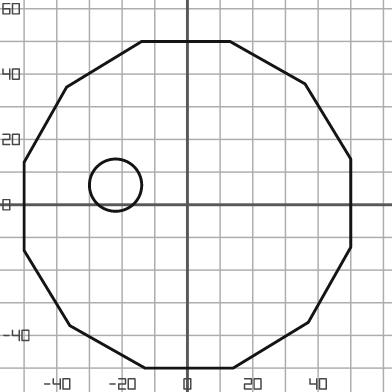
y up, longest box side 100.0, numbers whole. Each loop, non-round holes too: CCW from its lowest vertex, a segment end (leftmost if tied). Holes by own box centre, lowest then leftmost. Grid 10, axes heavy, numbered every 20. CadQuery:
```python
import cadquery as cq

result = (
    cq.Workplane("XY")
    .moveTo(-13.0, -50.0)
    .lineTo(14.0, -50.0)
    .lineTo(37.0, -36.0)
    .lineTo(50.0, -13.0)
    .lineTo(50.0, 14.0)
    .lineTo(36.0, 37.0)
    .lineTo(13.0, 50.0)
    .lineTo(-14.0, 50.0)
    .lineTo(-37.0, 36.0)
    .lineTo(-50.0, 13.0)
    .lineTo(-50.0, -14.0)
    .lineTo(-36.0, -37.0)
    .close()
    .moveTo(-22.0, 6.0)
    .circle(8.0)
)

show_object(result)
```